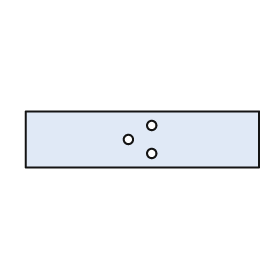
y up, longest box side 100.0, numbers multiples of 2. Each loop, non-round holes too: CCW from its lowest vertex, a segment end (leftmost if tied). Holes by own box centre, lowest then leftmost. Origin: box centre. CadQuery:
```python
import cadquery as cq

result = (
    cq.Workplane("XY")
    .moveTo(-50.0, -12.0)
    .lineTo(50.0, -12.0)
    .lineTo(50.0, 12.0)
    .lineTo(-50.0, 12.0)
    .close()
    .moveTo(4.0, -6.0)
    .circle(2.0)
    .moveTo(-6.0, 0.0)
    .circle(2.0)
    .moveTo(4.0, 6.0)
    .circle(2.0)
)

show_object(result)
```